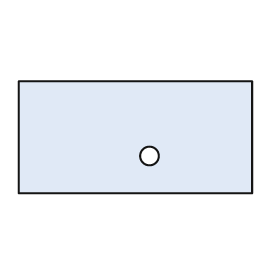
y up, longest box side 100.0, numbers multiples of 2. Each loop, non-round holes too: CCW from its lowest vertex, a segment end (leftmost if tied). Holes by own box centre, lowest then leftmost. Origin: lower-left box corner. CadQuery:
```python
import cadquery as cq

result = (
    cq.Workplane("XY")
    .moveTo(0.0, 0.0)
    .lineTo(100.0, 0.0)
    .lineTo(100.0, 48.0)
    .lineTo(0.0, 48.0)
    .close()
    .moveTo(56.0, 16.0)
    .circle(4.0)
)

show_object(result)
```